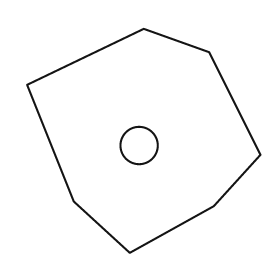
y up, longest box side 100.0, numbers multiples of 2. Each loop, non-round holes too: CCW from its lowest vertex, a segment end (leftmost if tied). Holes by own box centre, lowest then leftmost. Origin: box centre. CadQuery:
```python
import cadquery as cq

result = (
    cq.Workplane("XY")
    .moveTo(-6.0, -48.0)
    .lineTo(30.0, -28.0)
    .lineTo(50.0, -6.0)
    .lineTo(28.0, 38.0)
    .lineTo(0.0, 48.0)
    .lineTo(-50.0, 24.0)
    .lineTo(-30.0, -26.0)
    .close()
    .moveTo(-2.0, -2.0)
    .circle(8.0)
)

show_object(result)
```